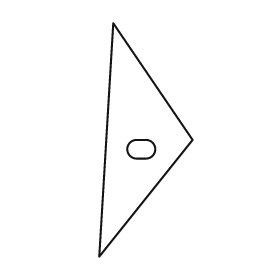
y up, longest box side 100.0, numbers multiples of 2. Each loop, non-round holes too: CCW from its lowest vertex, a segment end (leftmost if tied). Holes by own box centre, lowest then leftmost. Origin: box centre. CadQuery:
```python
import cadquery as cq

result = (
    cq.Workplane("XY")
    .moveTo(-20.0, -50.0)
    .lineTo(20.0, 0.0)
    .lineTo(-14.0, 50.0)
    .close()
    .moveTo(-4.0, -8.0)
    .lineTo(0.0, -8.0)
    .threePointArc((4.0, -4.0), (0.0, 0.0))
    .lineTo(-4.0, 0.0)
    .threePointArc((-8.0, -4.0), (-4.0, -8.0))
    .close()
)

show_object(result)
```